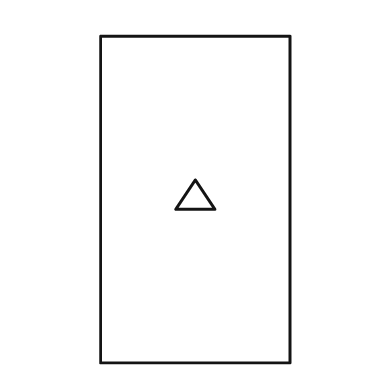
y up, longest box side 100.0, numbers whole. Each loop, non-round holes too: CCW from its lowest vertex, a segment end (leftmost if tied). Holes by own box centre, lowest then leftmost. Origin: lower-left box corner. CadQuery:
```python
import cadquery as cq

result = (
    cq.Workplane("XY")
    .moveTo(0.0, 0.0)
    .lineTo(58.0, 0.0)
    .lineTo(58.0, 100.0)
    .lineTo(0.0, 100.0)
    .close()
    .moveTo(23.0, 47.0)
    .lineTo(35.0, 47.0)
    .lineTo(29.0, 56.0)
    .close()
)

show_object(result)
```